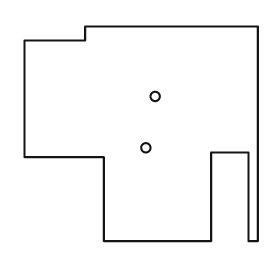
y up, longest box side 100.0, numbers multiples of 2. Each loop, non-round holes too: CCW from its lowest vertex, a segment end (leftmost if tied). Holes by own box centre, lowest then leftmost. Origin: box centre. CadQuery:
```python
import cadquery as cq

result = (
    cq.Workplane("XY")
    .moveTo(-16.0, -46.0)
    .lineTo(30.0, -46.0)
    .lineTo(30.0, -8.0)
    .lineTo(46.0, -8.0)
    .lineTo(46.0, -46.0)
    .lineTo(50.0, -46.0)
    .lineTo(50.0, 46.0)
    .lineTo(-24.0, 46.0)
    .lineTo(-24.0, 40.0)
    .lineTo(-50.0, 40.0)
    .lineTo(-50.0, -10.0)
    .lineTo(-16.0, -10.0)
    .close()
    .moveTo(2.0, -6.0)
    .circle(2.0)
    .moveTo(6.0, 16.0)
    .circle(2.0)
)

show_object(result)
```